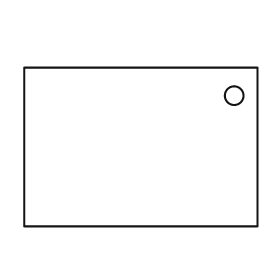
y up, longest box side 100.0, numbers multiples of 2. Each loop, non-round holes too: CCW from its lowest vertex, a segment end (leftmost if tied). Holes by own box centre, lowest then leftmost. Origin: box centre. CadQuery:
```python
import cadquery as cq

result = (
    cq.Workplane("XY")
    .moveTo(-50.0, -34.0)
    .lineTo(50.0, -34.0)
    .lineTo(50.0, 34.0)
    .lineTo(-50.0, 34.0)
    .close()
    .moveTo(40.0, 22.0)
    .circle(4.0)
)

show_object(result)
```